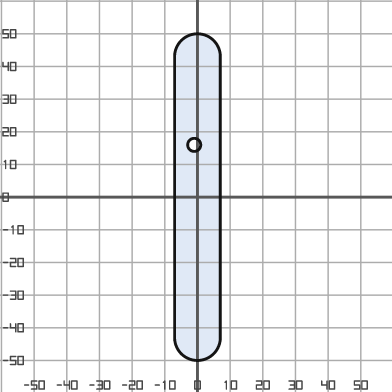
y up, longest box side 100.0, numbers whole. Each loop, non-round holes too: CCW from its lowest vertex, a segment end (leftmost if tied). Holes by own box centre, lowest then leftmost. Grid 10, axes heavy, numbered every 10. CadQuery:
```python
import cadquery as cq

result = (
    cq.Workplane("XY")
    .moveTo(-7.0, -43.0)
    .threePointArc((0.0, -50.0), (7.0, -43.0))
    .lineTo(7.0, 43.0)
    .threePointArc((0.0, 50.0), (-7.0, 43.0))
    .close()
    .moveTo(-1.0, 16.0)
    .circle(2.0)
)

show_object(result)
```